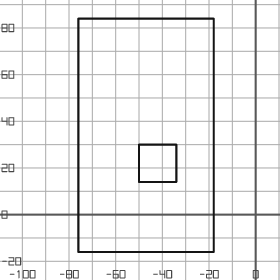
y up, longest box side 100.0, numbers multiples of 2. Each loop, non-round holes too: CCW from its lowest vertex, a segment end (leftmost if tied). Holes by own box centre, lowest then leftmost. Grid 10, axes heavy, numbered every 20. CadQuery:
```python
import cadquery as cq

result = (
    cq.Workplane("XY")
    .moveTo(-76.0, -16.0)
    .lineTo(-18.0, -16.0)
    .lineTo(-18.0, 84.0)
    .lineTo(-76.0, 84.0)
    .close()
    .moveTo(-50.0, 14.0)
    .lineTo(-34.0, 14.0)
    .lineTo(-34.0, 30.0)
    .lineTo(-50.0, 30.0)
    .close()
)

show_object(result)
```